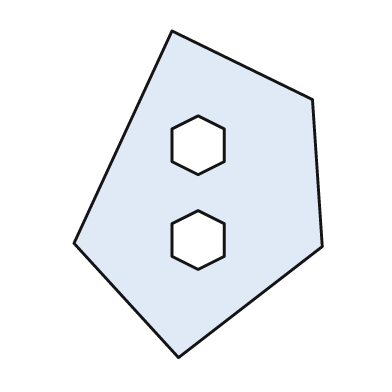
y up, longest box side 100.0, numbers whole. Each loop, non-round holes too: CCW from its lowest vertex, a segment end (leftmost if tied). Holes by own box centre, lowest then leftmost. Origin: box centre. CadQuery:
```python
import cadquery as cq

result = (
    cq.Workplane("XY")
    .moveTo(-6.0, -50.0)
    .lineTo(38.0, -16.0)
    .lineTo(35.0, 29.0)
    .lineTo(-8.0, 50.0)
    .lineTo(-38.0, -15.0)
    .close()
    .moveTo(0.0, -23.0)
    .lineTo(8.0, -19.0)
    .lineTo(8.0, -9.0)
    .lineTo(0.0, -5.0)
    .lineTo(-8.0, -9.0)
    .lineTo(-8.0, -19.0)
    .close()
    .moveTo(0.0, 6.0)
    .lineTo(8.0, 10.0)
    .lineTo(8.0, 20.0)
    .lineTo(0.0, 24.0)
    .lineTo(-8.0, 20.0)
    .lineTo(-8.0, 10.0)
    .close()
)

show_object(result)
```